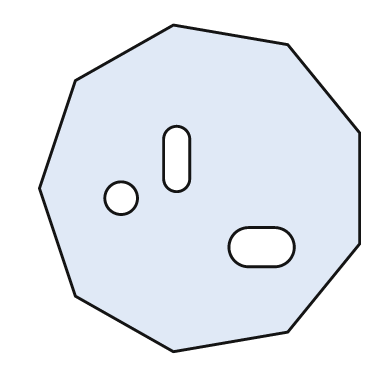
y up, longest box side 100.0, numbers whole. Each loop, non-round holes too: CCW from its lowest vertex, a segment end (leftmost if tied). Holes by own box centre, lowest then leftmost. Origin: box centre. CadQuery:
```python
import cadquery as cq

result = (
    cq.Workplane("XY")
    .moveTo(-8.0, -50.0)
    .lineTo(27.0, -44.0)
    .lineTo(49.0, -17.0)
    .lineTo(49.0, 17.0)
    .lineTo(27.0, 44.0)
    .lineTo(-8.0, 50.0)
    .lineTo(-38.0, 33.0)
    .lineTo(-49.0, 0.0)
    .lineTo(-38.0, -33.0)
    .close()
    .moveTo(15.0, -24.0)
    .lineTo(23.0, -24.0)
    .threePointArc((29.0, -18.0), (23.0, -12.0))
    .lineTo(15.0, -12.0)
    .threePointArc((9.0, -18.0), (15.0, -24.0))
    .close()
    .moveTo(-24.0, -3.0)
    .circle(5.0)
    .moveTo(-11.0, 3.0)
    .threePointArc((-7.0, -1.0), (-3.0, 3.0))
    .lineTo(-3.0, 15.0)
    .threePointArc((-7.0, 19.0), (-11.0, 15.0))
    .close()
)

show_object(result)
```